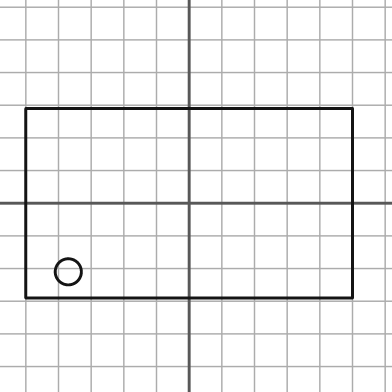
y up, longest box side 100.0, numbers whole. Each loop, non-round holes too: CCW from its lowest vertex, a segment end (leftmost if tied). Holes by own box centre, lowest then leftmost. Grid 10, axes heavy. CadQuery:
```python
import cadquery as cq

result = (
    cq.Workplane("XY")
    .moveTo(-50.0, -29.0)
    .lineTo(50.0, -29.0)
    .lineTo(50.0, 29.0)
    .lineTo(-50.0, 29.0)
    .close()
    .moveTo(-37.0, -21.0)
    .circle(4.0)
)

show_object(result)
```